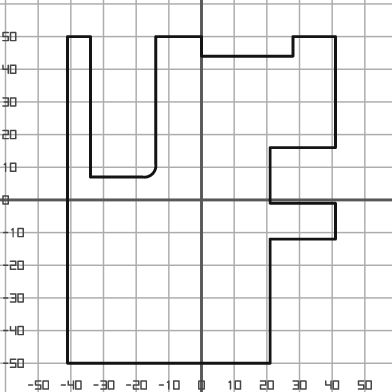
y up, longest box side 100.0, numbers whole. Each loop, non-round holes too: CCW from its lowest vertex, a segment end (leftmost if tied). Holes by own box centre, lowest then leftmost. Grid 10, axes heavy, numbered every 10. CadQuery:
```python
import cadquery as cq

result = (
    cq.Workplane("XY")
    .moveTo(-41.0, -50.0)
    .lineTo(21.0, -50.0)
    .lineTo(21.0, -12.0)
    .lineTo(41.0, -12.0)
    .lineTo(41.0, -1.0)
    .lineTo(21.0, -1.0)
    .lineTo(21.0, 16.0)
    .lineTo(41.0, 16.0)
    .lineTo(41.0, 50.0)
    .lineTo(28.0, 50.0)
    .lineTo(28.0, 44.0)
    .lineTo(0.0, 44.0)
    .lineTo(0.0, 50.0)
    .lineTo(-14.0, 50.0)
    .lineTo(-14.0, 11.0)
    .threePointArc((-15.0, 8.0), (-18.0, 7.0))
    .lineTo(-34.0, 7.0)
    .lineTo(-34.0, 50.0)
    .lineTo(-41.0, 50.0)
    .close()
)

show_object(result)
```